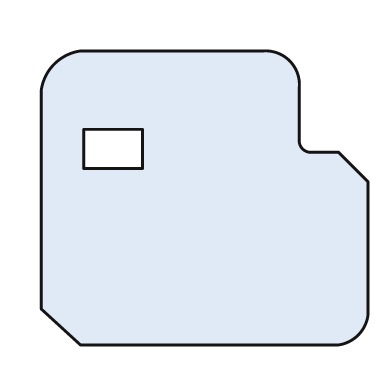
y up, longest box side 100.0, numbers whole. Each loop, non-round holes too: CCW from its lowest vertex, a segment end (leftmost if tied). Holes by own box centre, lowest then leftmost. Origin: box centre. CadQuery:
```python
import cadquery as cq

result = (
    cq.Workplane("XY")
    .moveTo(-38.0, -45.0)
    .lineTo(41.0, -45.0)
    .threePointArc((47.0, -42.0), (50.0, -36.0))
    .lineTo(50.0, 5.0)
    .lineTo(41.0, 14.0)
    .lineTo(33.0, 14.0)
    .threePointArc((30.0, 15.0), (29.0, 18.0))
    .lineTo(29.0, 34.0)
    .threePointArc((26.0, 42.0), (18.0, 45.0))
    .lineTo(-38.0, 45.0)
    .threePointArc((-46.0, 41.0), (-50.0, 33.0))
    .lineTo(-50.0, -34.0)
    .close()
    .moveTo(-37.0, 9.0)
    .lineTo(-19.0, 9.0)
    .lineTo(-19.0, 21.0)
    .lineTo(-37.0, 21.0)
    .close()
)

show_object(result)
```